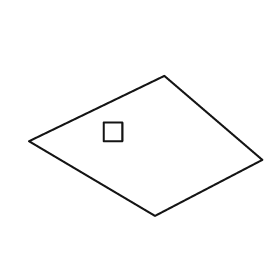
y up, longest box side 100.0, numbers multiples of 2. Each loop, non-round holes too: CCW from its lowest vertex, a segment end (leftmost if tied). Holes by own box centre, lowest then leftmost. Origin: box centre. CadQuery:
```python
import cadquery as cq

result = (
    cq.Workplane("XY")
    .moveTo(4.0, -30.0)
    .lineTo(50.0, -6.0)
    .lineTo(8.0, 30.0)
    .lineTo(-50.0, 2.0)
    .close()
    .moveTo(-18.0, 2.0)
    .lineTo(-10.0, 2.0)
    .lineTo(-10.0, 10.0)
    .lineTo(-18.0, 10.0)
    .close()
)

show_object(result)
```